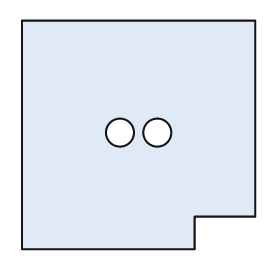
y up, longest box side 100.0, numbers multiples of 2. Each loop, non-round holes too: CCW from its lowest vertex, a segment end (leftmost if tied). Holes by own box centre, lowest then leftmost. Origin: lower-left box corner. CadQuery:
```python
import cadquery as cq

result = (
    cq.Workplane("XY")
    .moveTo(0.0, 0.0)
    .lineTo(74.0, 0.0)
    .lineTo(74.0, 14.0)
    .lineTo(100.0, 14.0)
    .lineTo(100.0, 98.0)
    .lineTo(0.0, 98.0)
    .close()
    .moveTo(42.0, 50.0)
    .circle(6.0)
    .moveTo(58.0, 50.0)
    .circle(6.0)
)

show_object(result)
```